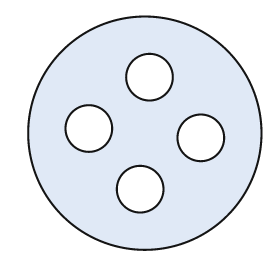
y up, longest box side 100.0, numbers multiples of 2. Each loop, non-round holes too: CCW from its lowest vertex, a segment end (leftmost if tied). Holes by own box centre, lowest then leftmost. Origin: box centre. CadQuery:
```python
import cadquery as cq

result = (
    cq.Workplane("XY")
    .moveTo(0.0, 0.0)
    .circle(50.0)
    .moveTo(-2.0, -24.0)
    .circle(10.0)
    .moveTo(24.0, -2.0)
    .circle(10.0)
    .moveTo(-24.0, 2.0)
    .circle(10.0)
    .moveTo(2.0, 24.0)
    .circle(10.0)
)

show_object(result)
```